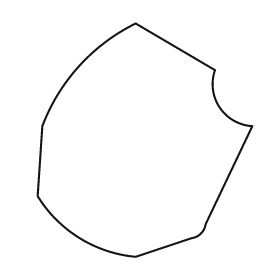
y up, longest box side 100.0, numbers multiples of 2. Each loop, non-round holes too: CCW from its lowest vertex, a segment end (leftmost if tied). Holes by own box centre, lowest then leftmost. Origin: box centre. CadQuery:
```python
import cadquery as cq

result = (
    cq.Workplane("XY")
    .moveTo(-4.0, -50.0)
    .lineTo(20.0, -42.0)
    .threePointArc((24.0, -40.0), (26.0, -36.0))
    .lineTo(46.0, 6.0)
    .threePointArc((32.0, 14.0), (30.0, 30.0))
    .lineTo(-4.0, 50.0)
    .threePointArc((-28.0, 32.0), (-44.0, 6.0))
    .lineTo(-46.0, -24.0)
    .threePointArc((-28.0, -42.0), (-4.0, -50.0))
    .close()
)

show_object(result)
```